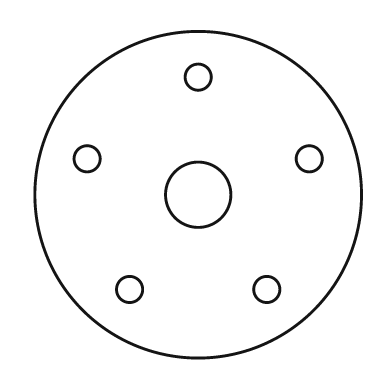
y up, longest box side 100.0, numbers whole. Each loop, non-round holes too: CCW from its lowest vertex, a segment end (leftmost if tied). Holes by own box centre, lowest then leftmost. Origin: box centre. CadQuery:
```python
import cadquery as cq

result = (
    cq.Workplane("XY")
    .moveTo(0.0, 0.0)
    .circle(50.0)
    .moveTo(-21.0, -29.0)
    .circle(4.0)
    .moveTo(21.0, -29.0)
    .circle(4.0)
    .moveTo(0.0, 0.0)
    .circle(10.0)
    .moveTo(-34.0, 11.0)
    .circle(4.0)
    .moveTo(34.0, 11.0)
    .circle(4.0)
    .moveTo(0.0, 36.0)
    .circle(4.0)
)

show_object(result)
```